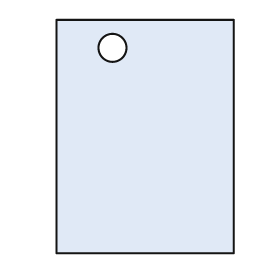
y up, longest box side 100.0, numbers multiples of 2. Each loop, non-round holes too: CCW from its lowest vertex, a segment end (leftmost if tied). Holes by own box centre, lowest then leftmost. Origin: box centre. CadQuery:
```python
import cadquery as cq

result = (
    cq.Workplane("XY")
    .moveTo(-38.0, -50.0)
    .lineTo(38.0, -50.0)
    .lineTo(38.0, 50.0)
    .lineTo(-38.0, 50.0)
    .close()
    .moveTo(-14.0, 38.0)
    .circle(6.0)
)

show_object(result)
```